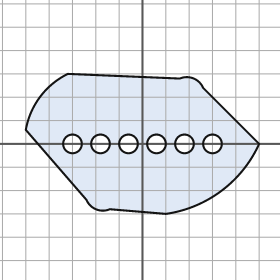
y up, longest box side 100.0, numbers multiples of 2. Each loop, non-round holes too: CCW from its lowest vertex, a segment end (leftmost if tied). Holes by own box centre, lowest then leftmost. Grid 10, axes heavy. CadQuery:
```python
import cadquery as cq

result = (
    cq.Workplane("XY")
    .moveTo(10.0, -30.0)
    .threePointArc((34.0, -20.0), (50.0, 0.0))
    .lineTo(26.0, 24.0)
    .threePointArc((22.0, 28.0), (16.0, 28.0))
    .lineTo(-32.0, 30.0)
    .threePointArc((-44.0, 20.0), (-50.0, 6.0))
    .lineTo(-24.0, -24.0)
    .threePointArc((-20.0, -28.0), (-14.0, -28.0))
    .close()
    .moveTo(-30.0, 0.0)
    .circle(4.0)
    .moveTo(-18.0, 0.0)
    .circle(4.0)
    .moveTo(-6.0, 0.0)
    .circle(4.0)
    .moveTo(6.0, 0.0)
    .circle(4.0)
    .moveTo(18.0, 0.0)
    .circle(4.0)
    .moveTo(30.0, 0.0)
    .circle(4.0)
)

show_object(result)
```